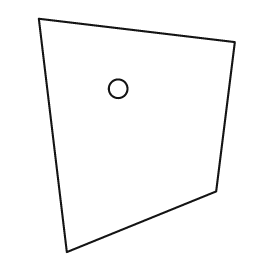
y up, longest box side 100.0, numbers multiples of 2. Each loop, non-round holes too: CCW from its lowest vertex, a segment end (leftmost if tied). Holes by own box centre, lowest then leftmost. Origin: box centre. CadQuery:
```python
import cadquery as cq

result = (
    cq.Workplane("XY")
    .moveTo(-30.0, -50.0)
    .lineTo(34.0, -24.0)
    .lineTo(42.0, 40.0)
    .lineTo(-42.0, 50.0)
    .close()
    .moveTo(-8.0, 20.0)
    .circle(4.0)
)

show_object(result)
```